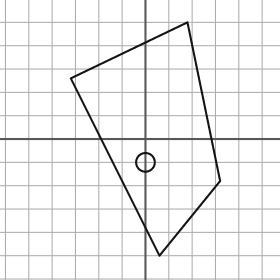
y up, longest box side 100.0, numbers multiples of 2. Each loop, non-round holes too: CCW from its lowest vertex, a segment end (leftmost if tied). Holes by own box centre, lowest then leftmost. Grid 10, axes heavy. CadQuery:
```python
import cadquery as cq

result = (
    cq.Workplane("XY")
    .moveTo(6.0, -50.0)
    .lineTo(32.0, -18.0)
    .lineTo(18.0, 50.0)
    .lineTo(-32.0, 26.0)
    .close()
    .moveTo(0.0, -10.0)
    .circle(4.0)
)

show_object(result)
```